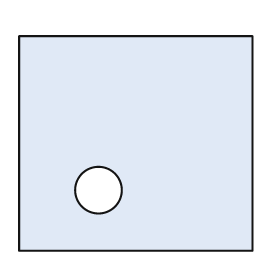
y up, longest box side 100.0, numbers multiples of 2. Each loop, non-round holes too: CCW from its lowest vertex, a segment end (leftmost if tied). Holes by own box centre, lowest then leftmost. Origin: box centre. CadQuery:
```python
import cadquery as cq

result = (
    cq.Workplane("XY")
    .moveTo(-50.0, -46.0)
    .lineTo(50.0, -46.0)
    .lineTo(50.0, 46.0)
    .lineTo(-50.0, 46.0)
    .close()
    .moveTo(-16.0, -20.0)
    .circle(10.0)
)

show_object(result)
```